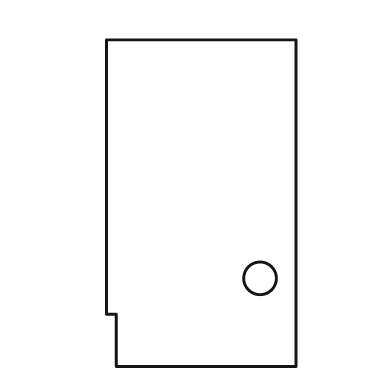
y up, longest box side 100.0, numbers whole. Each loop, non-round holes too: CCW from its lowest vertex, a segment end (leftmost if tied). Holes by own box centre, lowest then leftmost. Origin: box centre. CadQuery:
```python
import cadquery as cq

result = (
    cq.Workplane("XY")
    .moveTo(-26.0, -50.0)
    .lineTo(29.0, -50.0)
    .lineTo(29.0, 50.0)
    .lineTo(-29.0, 50.0)
    .lineTo(-29.0, -34.0)
    .lineTo(-26.0, -34.0)
    .close()
    .moveTo(18.0, -23.0)
    .circle(5.0)
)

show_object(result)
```